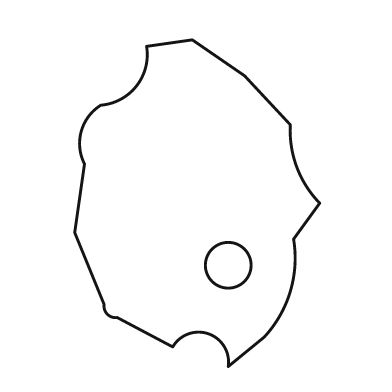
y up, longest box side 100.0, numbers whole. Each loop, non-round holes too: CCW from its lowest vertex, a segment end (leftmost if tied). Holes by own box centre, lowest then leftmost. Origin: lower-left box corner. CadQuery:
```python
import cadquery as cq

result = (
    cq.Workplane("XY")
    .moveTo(47.0, 0.0)
    .lineTo(58.0, 9.0)
    .threePointArc((66.0, 23.0), (67.0, 39.0))
    .lineTo(75.0, 50.0)
    .threePointArc((68.0, 61.0), (66.0, 74.0))
    .lineTo(52.0, 89.0)
    .lineTo(36.0, 100.0)
    .lineTo(22.0, 98.0)
    .threePointArc((19.0, 86.0), (8.0, 80.0))
    .threePointArc((2.0, 72.0), (3.0, 62.0))
    .lineTo(0.0, 41.0)
    .lineTo(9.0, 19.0)
    .threePointArc((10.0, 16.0), (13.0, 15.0))
    .lineTo(30.0, 6.0)
    .threePointArc((41.0, 10.0), (47.0, 0.0))
    .close()
    .moveTo(47.0, 31.0)
    .circle(7.0)
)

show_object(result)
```